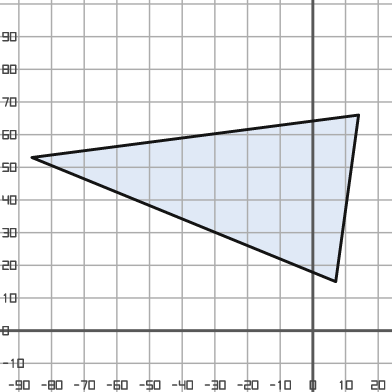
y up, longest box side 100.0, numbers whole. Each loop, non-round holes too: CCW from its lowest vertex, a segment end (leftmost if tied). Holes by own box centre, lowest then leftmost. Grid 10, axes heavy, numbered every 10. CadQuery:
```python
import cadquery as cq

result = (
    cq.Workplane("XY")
    .moveTo(7.0, 15.0)
    .lineTo(14.0, 66.0)
    .lineTo(-86.0, 53.0)
    .close()
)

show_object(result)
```